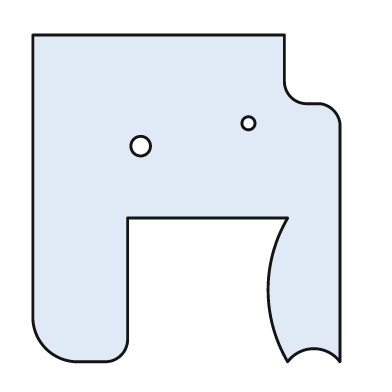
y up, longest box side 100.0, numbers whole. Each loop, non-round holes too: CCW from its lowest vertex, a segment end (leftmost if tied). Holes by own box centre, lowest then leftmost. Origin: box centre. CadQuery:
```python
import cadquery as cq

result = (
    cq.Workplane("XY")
    .moveTo(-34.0, -50.0)
    .lineTo(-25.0, -50.0)
    .threePointArc((-20.0, -48.0), (-18.0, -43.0))
    .lineTo(-18.0, -6.0)
    .lineTo(31.0, -6.0)
    .threePointArc((25.0, -28.0), (31.0, -50.0))
    .threePointArc((39.0, -46.0), (47.0, -50.0))
    .lineTo(47.0, 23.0)
    .threePointArc((45.0, 27.0), (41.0, 29.0))
    .lineTo(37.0, 29.0)
    .threePointArc((32.0, 31.0), (30.0, 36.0))
    .lineTo(30.0, 50.0)
    .lineTo(-47.0, 50.0)
    .lineTo(-47.0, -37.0)
    .threePointArc((-43.0, -46.0), (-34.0, -50.0))
    .close()
    .moveTo(-14.0, 16.0)
    .circle(3.0)
    .moveTo(19.0, 23.0)
    .circle(2.0)
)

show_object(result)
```